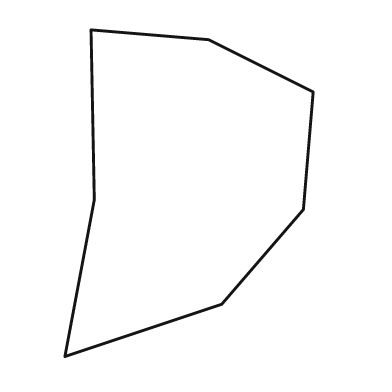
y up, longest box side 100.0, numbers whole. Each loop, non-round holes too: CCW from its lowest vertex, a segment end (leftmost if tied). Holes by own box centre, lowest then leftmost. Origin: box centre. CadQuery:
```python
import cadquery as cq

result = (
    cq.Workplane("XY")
    .moveTo(-38.0, -50.0)
    .lineTo(10.0, -34.0)
    .lineTo(35.0, -5.0)
    .lineTo(38.0, 31.0)
    .lineTo(6.0, 47.0)
    .lineTo(-30.0, 50.0)
    .lineTo(-29.0, -2.0)
    .close()
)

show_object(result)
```